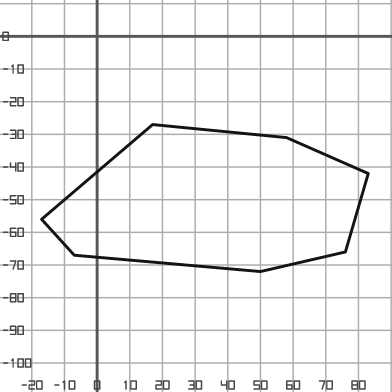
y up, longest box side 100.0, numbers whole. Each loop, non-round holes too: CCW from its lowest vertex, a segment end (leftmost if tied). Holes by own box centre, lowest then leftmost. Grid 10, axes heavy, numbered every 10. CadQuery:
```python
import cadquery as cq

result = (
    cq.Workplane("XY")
    .moveTo(50.0, -72.0)
    .lineTo(76.0, -66.0)
    .lineTo(83.0, -42.0)
    .lineTo(58.0, -31.0)
    .lineTo(17.0, -27.0)
    .lineTo(-17.0, -56.0)
    .lineTo(-7.0, -67.0)
    .close()
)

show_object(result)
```